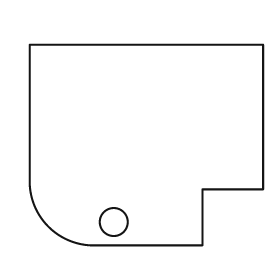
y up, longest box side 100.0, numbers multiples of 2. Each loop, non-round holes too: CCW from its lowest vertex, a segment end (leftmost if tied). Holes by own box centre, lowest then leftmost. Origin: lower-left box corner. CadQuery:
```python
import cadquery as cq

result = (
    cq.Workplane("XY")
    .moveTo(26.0, 0.0)
    .lineTo(74.0, 0.0)
    .lineTo(74.0, 24.0)
    .lineTo(100.0, 24.0)
    .lineTo(100.0, 86.0)
    .lineTo(0.0, 86.0)
    .lineTo(0.0, 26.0)
    .threePointArc((8.0, 8.0), (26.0, 0.0))
    .close()
    .moveTo(36.0, 10.0)
    .circle(6.0)
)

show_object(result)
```